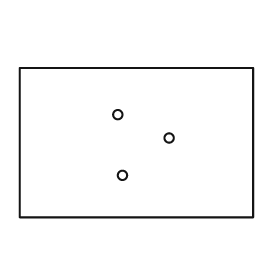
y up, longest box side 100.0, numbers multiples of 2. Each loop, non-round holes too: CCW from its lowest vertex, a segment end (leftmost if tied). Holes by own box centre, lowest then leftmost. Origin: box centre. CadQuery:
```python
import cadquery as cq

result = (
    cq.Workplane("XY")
    .moveTo(-50.0, -32.0)
    .lineTo(50.0, -32.0)
    .lineTo(50.0, 32.0)
    .lineTo(-50.0, 32.0)
    .close()
    .moveTo(-6.0, -14.0)
    .circle(2.0)
    .moveTo(14.0, 2.0)
    .circle(2.0)
    .moveTo(-8.0, 12.0)
    .circle(2.0)
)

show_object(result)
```